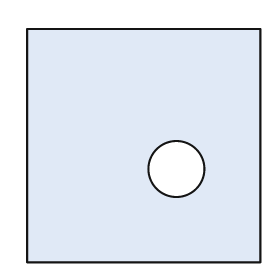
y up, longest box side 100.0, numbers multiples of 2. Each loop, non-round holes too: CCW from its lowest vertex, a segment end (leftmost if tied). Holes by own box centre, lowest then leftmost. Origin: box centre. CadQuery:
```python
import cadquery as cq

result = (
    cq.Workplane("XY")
    .moveTo(-50.0, -50.0)
    .lineTo(50.0, -50.0)
    .lineTo(50.0, 50.0)
    .lineTo(-50.0, 50.0)
    .close()
    .moveTo(14.0, -10.0)
    .circle(12.0)
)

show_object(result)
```